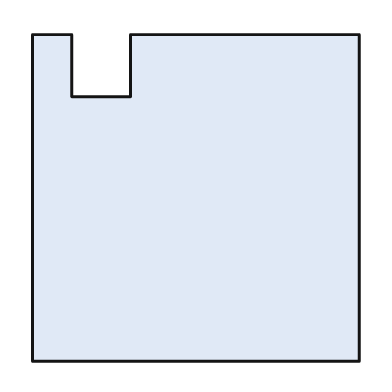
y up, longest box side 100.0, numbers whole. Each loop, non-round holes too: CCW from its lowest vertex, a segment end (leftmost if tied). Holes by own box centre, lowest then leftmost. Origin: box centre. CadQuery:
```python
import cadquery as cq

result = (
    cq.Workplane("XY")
    .moveTo(-50.0, -50.0)
    .lineTo(50.0, -50.0)
    .lineTo(50.0, 50.0)
    .lineTo(-20.0, 50.0)
    .lineTo(-20.0, 31.0)
    .lineTo(-38.0, 31.0)
    .lineTo(-38.0, 50.0)
    .lineTo(-50.0, 50.0)
    .close()
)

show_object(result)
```